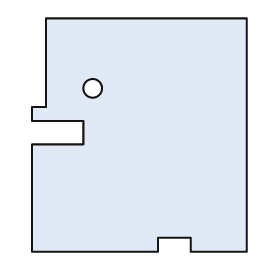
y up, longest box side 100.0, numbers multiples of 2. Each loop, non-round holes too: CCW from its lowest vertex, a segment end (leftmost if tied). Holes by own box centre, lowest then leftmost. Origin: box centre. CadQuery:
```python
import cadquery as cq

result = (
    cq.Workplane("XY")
    .moveTo(-46.0, -50.0)
    .lineTo(8.0, -50.0)
    .lineTo(8.0, -44.0)
    .lineTo(22.0, -44.0)
    .lineTo(22.0, -50.0)
    .lineTo(46.0, -50.0)
    .lineTo(46.0, 50.0)
    .lineTo(-40.0, 50.0)
    .lineTo(-40.0, 12.0)
    .lineTo(-46.0, 12.0)
    .lineTo(-46.0, 6.0)
    .lineTo(-24.0, 6.0)
    .lineTo(-24.0, -4.0)
    .lineTo(-46.0, -4.0)
    .close()
    .moveTo(-20.0, 20.0)
    .circle(4.0)
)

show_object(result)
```